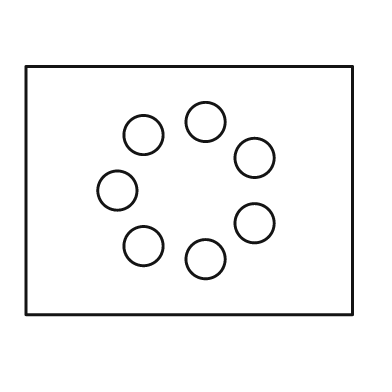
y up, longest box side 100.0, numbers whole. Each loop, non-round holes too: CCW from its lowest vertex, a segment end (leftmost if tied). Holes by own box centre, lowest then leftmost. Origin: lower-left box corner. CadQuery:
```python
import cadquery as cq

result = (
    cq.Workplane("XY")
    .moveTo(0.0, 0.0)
    .lineTo(100.0, 0.0)
    .lineTo(100.0, 76.0)
    .lineTo(0.0, 76.0)
    .close()
    .moveTo(55.0, 17.0)
    .circle(6.0)
    .moveTo(36.0, 21.0)
    .circle(6.0)
    .moveTo(70.0, 28.0)
    .circle(6.0)
    .moveTo(28.0, 38.0)
    .circle(6.0)
    .moveTo(70.0, 48.0)
    .circle(6.0)
    .moveTo(36.0, 55.0)
    .circle(6.0)
    .moveTo(55.0, 59.0)
    .circle(6.0)
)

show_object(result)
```